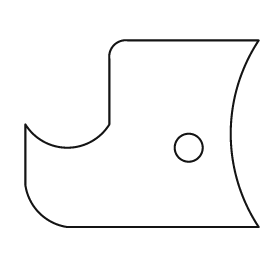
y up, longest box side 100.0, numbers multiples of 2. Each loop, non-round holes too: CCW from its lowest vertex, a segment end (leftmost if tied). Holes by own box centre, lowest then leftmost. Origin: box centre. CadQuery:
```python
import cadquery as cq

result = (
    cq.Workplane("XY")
    .moveTo(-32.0, -40.0)
    .lineTo(50.0, -40.0)
    .threePointArc((38.0, 0.0), (50.0, 40.0))
    .lineTo(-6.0, 40.0)
    .threePointArc((-12.0, 38.0), (-14.0, 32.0))
    .lineTo(-14.0, 4.0)
    .threePointArc((-32.0, -6.0), (-50.0, 4.0))
    .lineTo(-50.0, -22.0)
    .threePointArc((-44.0, -34.0), (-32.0, -40.0))
    .close()
    .moveTo(20.0, -6.0)
    .circle(6.0)
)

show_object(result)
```